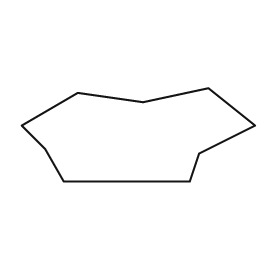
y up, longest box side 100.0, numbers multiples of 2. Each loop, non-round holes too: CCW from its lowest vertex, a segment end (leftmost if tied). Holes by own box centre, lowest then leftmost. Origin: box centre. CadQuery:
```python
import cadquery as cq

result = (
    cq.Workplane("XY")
    .moveTo(-32.0, -20.0)
    .lineTo(22.0, -20.0)
    .lineTo(26.0, -8.0)
    .lineTo(50.0, 4.0)
    .lineTo(30.0, 20.0)
    .lineTo(2.0, 14.0)
    .lineTo(-26.0, 18.0)
    .lineTo(-50.0, 4.0)
    .lineTo(-40.0, -6.0)
    .close()
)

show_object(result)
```